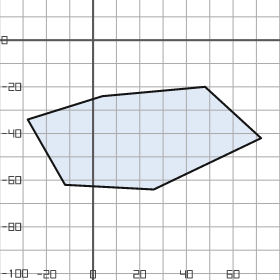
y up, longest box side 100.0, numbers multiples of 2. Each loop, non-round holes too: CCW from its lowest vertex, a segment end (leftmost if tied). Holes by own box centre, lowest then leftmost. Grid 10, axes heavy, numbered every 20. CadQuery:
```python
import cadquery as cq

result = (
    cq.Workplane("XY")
    .moveTo(26.0, -64.0)
    .lineTo(72.0, -42.0)
    .lineTo(48.0, -20.0)
    .lineTo(4.0, -24.0)
    .lineTo(-28.0, -34.0)
    .lineTo(-12.0, -62.0)
    .close()
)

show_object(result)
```